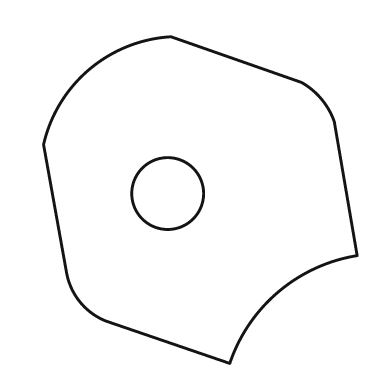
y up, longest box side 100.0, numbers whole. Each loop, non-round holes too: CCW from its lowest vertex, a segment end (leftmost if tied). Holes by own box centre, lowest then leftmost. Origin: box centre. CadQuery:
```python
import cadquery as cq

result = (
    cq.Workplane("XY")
    .moveTo(9.0, -50.0)
    .threePointArc((24.0, -28.0), (48.0, -17.0))
    .lineTo(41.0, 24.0)
    .threePointArc((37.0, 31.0), (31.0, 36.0))
    .lineTo(-9.0, 50.0)
    .threePointArc((-34.0, 40.0), (-48.0, 17.0))
    .lineTo(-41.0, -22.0)
    .threePointArc((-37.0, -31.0), (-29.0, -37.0))
    .close()
    .moveTo(-10.0, 2.0)
    .circle(11.0)
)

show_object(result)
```